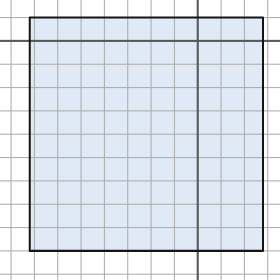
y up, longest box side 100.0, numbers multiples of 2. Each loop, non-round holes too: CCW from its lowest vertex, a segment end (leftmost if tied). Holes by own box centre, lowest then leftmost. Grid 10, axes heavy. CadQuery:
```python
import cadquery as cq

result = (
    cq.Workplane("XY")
    .moveTo(-72.0, -90.0)
    .lineTo(28.0, -90.0)
    .lineTo(28.0, 10.0)
    .lineTo(-72.0, 10.0)
    .close()
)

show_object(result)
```